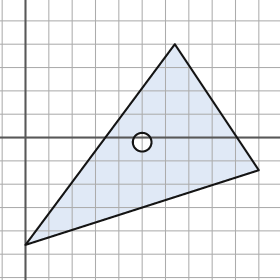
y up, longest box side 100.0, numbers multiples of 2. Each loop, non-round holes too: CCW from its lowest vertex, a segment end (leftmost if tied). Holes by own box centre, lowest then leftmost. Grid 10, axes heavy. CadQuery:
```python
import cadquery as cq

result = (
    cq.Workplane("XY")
    .moveTo(0.0, -46.0)
    .lineTo(100.0, -14.0)
    .lineTo(64.0, 40.0)
    .close()
    .moveTo(50.0, -2.0)
    .circle(4.0)
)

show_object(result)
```